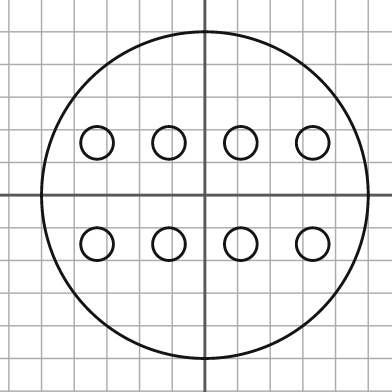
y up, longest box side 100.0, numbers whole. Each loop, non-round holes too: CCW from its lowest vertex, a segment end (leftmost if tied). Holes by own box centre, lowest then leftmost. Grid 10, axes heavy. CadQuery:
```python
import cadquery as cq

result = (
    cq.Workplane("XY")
    .moveTo(0.0, 0.0)
    .circle(50.0)
    .moveTo(-33.0, -15.0)
    .circle(5.0)
    .moveTo(-11.0, -15.0)
    .circle(5.0)
    .moveTo(11.0, -15.0)
    .circle(5.0)
    .moveTo(33.0, -15.0)
    .circle(5.0)
    .moveTo(-33.0, 16.0)
    .circle(5.0)
    .moveTo(-11.0, 16.0)
    .circle(5.0)
    .moveTo(11.0, 16.0)
    .circle(5.0)
    .moveTo(33.0, 16.0)
    .circle(5.0)
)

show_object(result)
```